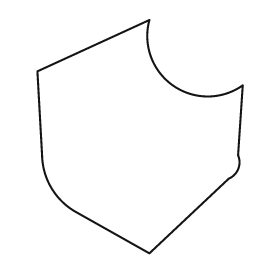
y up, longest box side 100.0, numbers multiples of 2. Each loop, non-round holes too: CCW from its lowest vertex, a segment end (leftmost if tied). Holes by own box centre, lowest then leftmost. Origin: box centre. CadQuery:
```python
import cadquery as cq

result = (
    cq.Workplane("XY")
    .moveTo(4.0, -50.0)
    .lineTo(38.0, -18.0)
    .threePointArc((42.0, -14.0), (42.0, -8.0))
    .lineTo(44.0, 22.0)
    .threePointArc((14.0, 22.0), (4.0, 50.0))
    .lineTo(-44.0, 28.0)
    .lineTo(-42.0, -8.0)
    .threePointArc((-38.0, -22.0), (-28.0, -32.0))
    .close()
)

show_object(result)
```